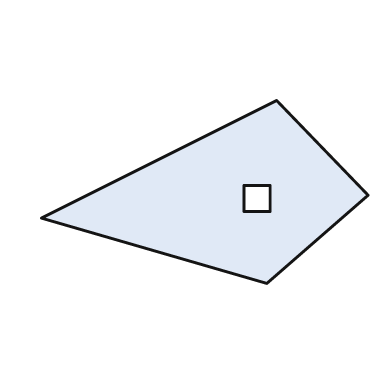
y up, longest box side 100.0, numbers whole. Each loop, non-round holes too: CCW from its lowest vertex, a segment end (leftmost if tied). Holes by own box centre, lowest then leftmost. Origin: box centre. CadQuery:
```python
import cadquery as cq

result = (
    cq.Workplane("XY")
    .moveTo(19.0, -28.0)
    .lineTo(50.0, -1.0)
    .lineTo(22.0, 28.0)
    .lineTo(-50.0, -8.0)
    .close()
    .moveTo(12.0, -6.0)
    .lineTo(20.0, -6.0)
    .lineTo(20.0, 2.0)
    .lineTo(12.0, 2.0)
    .close()
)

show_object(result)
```